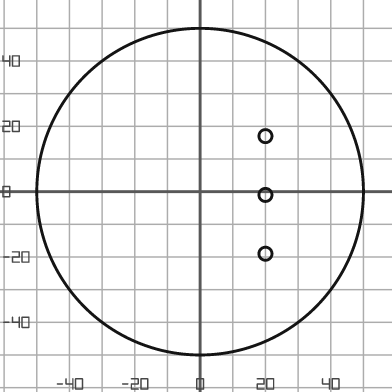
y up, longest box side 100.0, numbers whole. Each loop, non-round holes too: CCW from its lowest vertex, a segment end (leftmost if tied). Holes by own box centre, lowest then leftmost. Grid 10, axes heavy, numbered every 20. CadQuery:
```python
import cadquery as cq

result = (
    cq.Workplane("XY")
    .moveTo(0.0, 0.0)
    .circle(50.0)
    .moveTo(20.0, -19.0)
    .circle(2.0)
    .moveTo(20.0, -1.0)
    .circle(2.0)
    .moveTo(20.0, 17.0)
    .circle(2.0)
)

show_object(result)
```